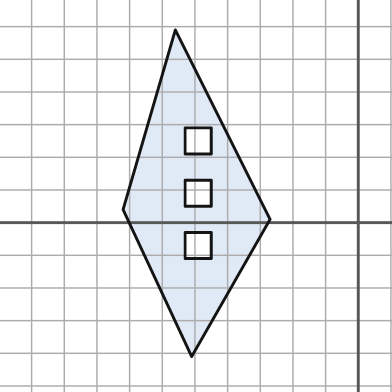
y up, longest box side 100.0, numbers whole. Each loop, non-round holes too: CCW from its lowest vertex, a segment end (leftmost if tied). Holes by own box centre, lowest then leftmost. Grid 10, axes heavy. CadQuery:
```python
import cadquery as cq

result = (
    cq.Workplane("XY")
    .moveTo(-51.0, -41.0)
    .lineTo(-27.0, 1.0)
    .lineTo(-56.0, 59.0)
    .lineTo(-72.0, 4.0)
    .close()
    .moveTo(-53.0, -11.0)
    .lineTo(-45.0, -11.0)
    .lineTo(-45.0, -3.0)
    .lineTo(-53.0, -3.0)
    .close()
    .moveTo(-53.0, 5.0)
    .lineTo(-45.0, 5.0)
    .lineTo(-45.0, 13.0)
    .lineTo(-53.0, 13.0)
    .close()
    .moveTo(-53.0, 21.0)
    .lineTo(-45.0, 21.0)
    .lineTo(-45.0, 29.0)
    .lineTo(-53.0, 29.0)
    .close()
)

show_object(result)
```